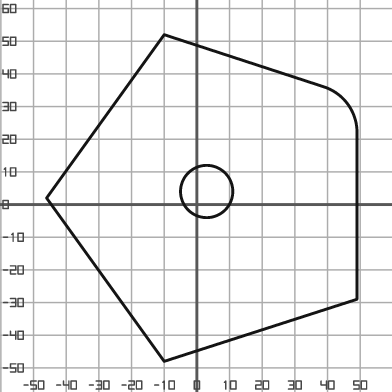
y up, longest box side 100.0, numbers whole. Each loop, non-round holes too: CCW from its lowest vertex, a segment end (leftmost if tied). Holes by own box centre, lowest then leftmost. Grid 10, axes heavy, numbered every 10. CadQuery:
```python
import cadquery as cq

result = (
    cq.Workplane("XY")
    .moveTo(-10.0, -48.0)
    .lineTo(49.0, -29.0)
    .lineTo(49.0, 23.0)
    .threePointArc((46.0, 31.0), (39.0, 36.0))
    .lineTo(-10.0, 52.0)
    .lineTo(-46.0, 2.0)
    .close()
    .moveTo(3.0, 4.0)
    .circle(8.0)
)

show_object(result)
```